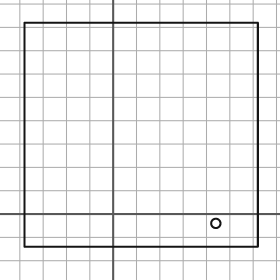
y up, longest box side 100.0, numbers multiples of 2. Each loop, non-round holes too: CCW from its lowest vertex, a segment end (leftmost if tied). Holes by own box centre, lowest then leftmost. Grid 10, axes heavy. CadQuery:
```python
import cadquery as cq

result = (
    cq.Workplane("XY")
    .moveTo(-38.0, -14.0)
    .lineTo(62.0, -14.0)
    .lineTo(62.0, 82.0)
    .lineTo(-38.0, 82.0)
    .close()
    .moveTo(44.0, -4.0)
    .circle(2.0)
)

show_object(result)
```